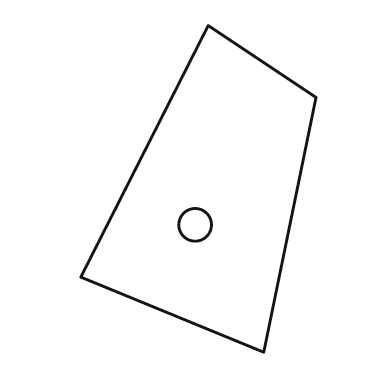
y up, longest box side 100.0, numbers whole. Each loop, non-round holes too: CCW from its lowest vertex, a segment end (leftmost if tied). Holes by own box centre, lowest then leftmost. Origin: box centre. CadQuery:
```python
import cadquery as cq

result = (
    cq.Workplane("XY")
    .moveTo(20.0, -50.0)
    .lineTo(36.0, 28.0)
    .lineTo(3.0, 50.0)
    .lineTo(-36.0, -27.0)
    .close()
    .moveTo(-1.0, -11.0)
    .circle(5.0)
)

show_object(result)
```